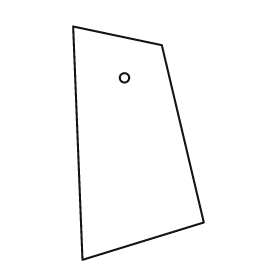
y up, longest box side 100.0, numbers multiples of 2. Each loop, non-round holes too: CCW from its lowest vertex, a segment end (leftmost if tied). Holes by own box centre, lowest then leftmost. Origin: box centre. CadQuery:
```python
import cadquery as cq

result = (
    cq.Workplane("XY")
    .moveTo(-24.0, -50.0)
    .lineTo(28.0, -34.0)
    .lineTo(10.0, 42.0)
    .lineTo(-28.0, 50.0)
    .close()
    .moveTo(-6.0, 28.0)
    .circle(2.0)
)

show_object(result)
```